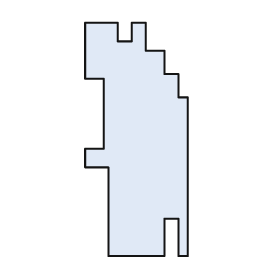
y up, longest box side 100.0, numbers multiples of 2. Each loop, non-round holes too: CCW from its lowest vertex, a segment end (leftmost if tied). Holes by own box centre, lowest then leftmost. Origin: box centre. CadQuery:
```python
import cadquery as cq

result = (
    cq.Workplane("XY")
    .moveTo(-12.0, -50.0)
    .lineTo(12.0, -50.0)
    .lineTo(12.0, -34.0)
    .lineTo(18.0, -34.0)
    .lineTo(18.0, -50.0)
    .lineTo(22.0, -50.0)
    .lineTo(22.0, 18.0)
    .lineTo(18.0, 18.0)
    .lineTo(18.0, 28.0)
    .lineTo(12.0, 28.0)
    .lineTo(12.0, 38.0)
    .lineTo(4.0, 38.0)
    .lineTo(4.0, 50.0)
    .lineTo(-2.0, 50.0)
    .lineTo(-2.0, 42.0)
    .lineTo(-8.0, 42.0)
    .lineTo(-8.0, 50.0)
    .lineTo(-22.0, 50.0)
    .lineTo(-22.0, 26.0)
    .lineTo(-14.0, 26.0)
    .lineTo(-14.0, -4.0)
    .lineTo(-22.0, -4.0)
    .lineTo(-22.0, -12.0)
    .lineTo(-12.0, -12.0)
    .close()
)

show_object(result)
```